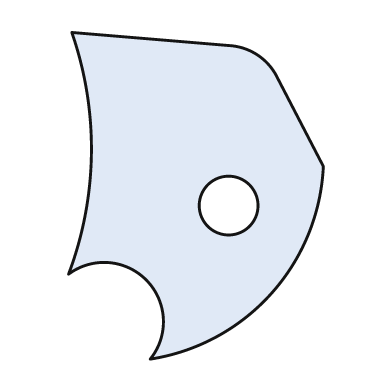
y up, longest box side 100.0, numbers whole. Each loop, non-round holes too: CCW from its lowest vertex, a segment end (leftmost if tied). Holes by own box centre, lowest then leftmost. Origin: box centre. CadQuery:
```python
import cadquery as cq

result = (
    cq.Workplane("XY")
    .moveTo(-14.0, -50.0)
    .threePointArc((23.0, -30.0), (39.0, 9.0))
    .lineTo(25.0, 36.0)
    .threePointArc((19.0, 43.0), (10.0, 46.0))
    .lineTo(-38.0, 50.0)
    .threePointArc((-32.0, 13.0), (-39.0, -24.0))
    .threePointArc((-15.0, -26.0), (-14.0, -50.0))
    .close()
    .moveTo(10.0, -3.0)
    .circle(9.0)
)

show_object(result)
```